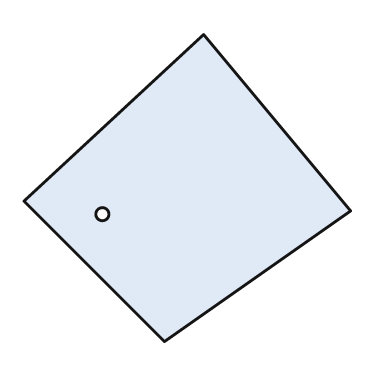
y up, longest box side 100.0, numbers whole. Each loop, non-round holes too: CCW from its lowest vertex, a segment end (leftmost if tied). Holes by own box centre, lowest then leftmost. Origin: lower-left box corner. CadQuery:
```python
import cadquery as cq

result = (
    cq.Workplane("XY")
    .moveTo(43.0, 0.0)
    .lineTo(100.0, 40.0)
    .lineTo(55.0, 94.0)
    .lineTo(0.0, 43.0)
    .close()
    .moveTo(24.0, 39.0)
    .circle(2.0)
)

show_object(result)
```